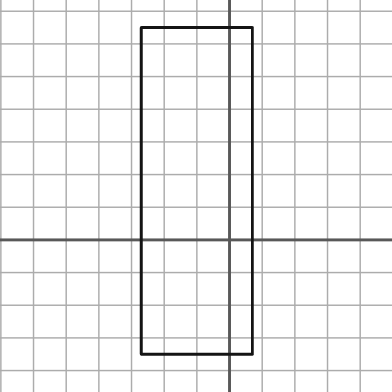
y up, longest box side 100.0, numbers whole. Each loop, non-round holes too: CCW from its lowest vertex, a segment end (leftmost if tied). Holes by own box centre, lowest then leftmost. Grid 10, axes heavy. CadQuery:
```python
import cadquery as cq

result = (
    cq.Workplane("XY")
    .moveTo(-27.0, -35.0)
    .lineTo(7.0, -35.0)
    .lineTo(7.0, 65.0)
    .lineTo(-27.0, 65.0)
    .close()
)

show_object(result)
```